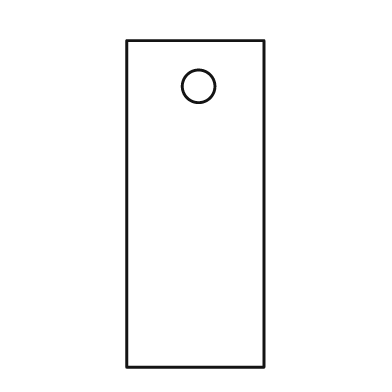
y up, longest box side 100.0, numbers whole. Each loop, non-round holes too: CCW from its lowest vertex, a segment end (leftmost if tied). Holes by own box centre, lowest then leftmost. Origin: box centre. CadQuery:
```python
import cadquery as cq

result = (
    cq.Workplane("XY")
    .moveTo(-21.0, -50.0)
    .lineTo(21.0, -50.0)
    .lineTo(21.0, 50.0)
    .lineTo(-21.0, 50.0)
    .close()
    .moveTo(1.0, 36.0)
    .circle(5.0)
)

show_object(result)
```